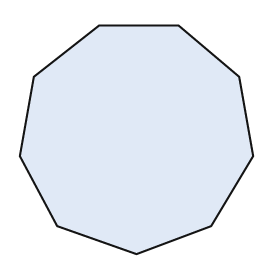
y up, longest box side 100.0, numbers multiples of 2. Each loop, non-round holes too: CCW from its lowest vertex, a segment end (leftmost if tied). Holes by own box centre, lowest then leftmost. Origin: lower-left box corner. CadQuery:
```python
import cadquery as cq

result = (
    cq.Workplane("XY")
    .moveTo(50.0, 0.0)
    .lineTo(82.0, 12.0)
    .lineTo(100.0, 42.0)
    .lineTo(94.0, 76.0)
    .lineTo(68.0, 98.0)
    .lineTo(34.0, 98.0)
    .lineTo(6.0, 76.0)
    .lineTo(0.0, 42.0)
    .lineTo(16.0, 12.0)
    .close()
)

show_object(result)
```